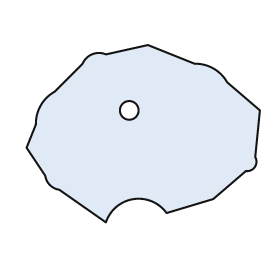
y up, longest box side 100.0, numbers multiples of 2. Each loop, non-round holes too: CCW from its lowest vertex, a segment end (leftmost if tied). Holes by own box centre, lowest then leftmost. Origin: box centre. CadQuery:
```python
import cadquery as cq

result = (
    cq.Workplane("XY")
    .moveTo(-16.0, -38.0)
    .threePointArc((-4.0, -28.0), (10.0, -34.0))
    .lineTo(30.0, -28.0)
    .lineTo(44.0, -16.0)
    .threePointArc((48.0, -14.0), (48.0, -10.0))
    .lineTo(50.0, 10.0)
    .lineTo(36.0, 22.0)
    .threePointArc((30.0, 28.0), (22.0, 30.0))
    .lineTo(2.0, 38.0)
    .lineTo(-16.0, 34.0)
    .threePointArc((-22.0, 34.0), (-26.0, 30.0))
    .lineTo(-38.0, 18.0)
    .threePointArc((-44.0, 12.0), (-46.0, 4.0))
    .lineTo(-50.0, -6.0)
    .lineTo(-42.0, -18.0)
    .threePointArc((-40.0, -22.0), (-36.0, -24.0))
    .close()
    .moveTo(-6.0, 10.0)
    .circle(4.0)
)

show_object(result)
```